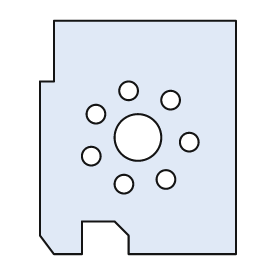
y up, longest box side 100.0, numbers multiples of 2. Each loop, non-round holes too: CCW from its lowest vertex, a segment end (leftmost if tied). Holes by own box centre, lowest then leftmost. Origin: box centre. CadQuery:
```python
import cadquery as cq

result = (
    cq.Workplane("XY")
    .moveTo(-36.0, -50.0)
    .lineTo(-24.0, -50.0)
    .lineTo(-24.0, -36.0)
    .lineTo(-10.0, -36.0)
    .lineTo(-4.0, -42.0)
    .lineTo(-4.0, -50.0)
    .lineTo(42.0, -50.0)
    .lineTo(42.0, 50.0)
    .lineTo(-36.0, 50.0)
    .lineTo(-36.0, 24.0)
    .lineTo(-42.0, 24.0)
    .lineTo(-42.0, -42.0)
    .close()
    .moveTo(-6.0, -20.0)
    .circle(4.0)
    .moveTo(12.0, -18.0)
    .circle(4.0)
    .moveTo(-20.0, -8.0)
    .circle(4.0)
    .moveTo(22.0, -2.0)
    .circle(4.0)
    .moveTo(0.0, 0.0)
    .circle(10.0)
    .moveTo(-18.0, 10.0)
    .circle(4.0)
    .moveTo(14.0, 16.0)
    .circle(4.0)
    .moveTo(-4.0, 20.0)
    .circle(4.0)
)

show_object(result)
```